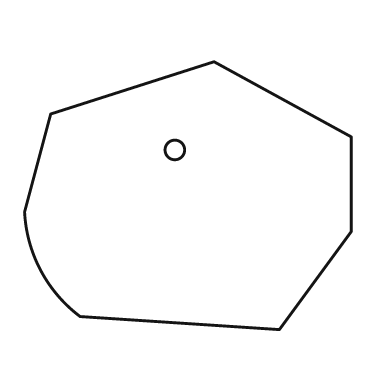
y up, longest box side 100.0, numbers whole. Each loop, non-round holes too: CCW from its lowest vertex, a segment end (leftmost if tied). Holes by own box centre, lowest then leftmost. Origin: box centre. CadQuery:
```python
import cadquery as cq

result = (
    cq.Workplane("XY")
    .moveTo(28.0, -41.0)
    .lineTo(50.0, -11.0)
    .lineTo(50.0, 18.0)
    .lineTo(8.0, 41.0)
    .lineTo(-42.0, 25.0)
    .lineTo(-50.0, -5.0)
    .threePointArc((-45.0, -23.0), (-33.0, -37.0))
    .close()
    .moveTo(-4.0, 14.0)
    .circle(3.0)
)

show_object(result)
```